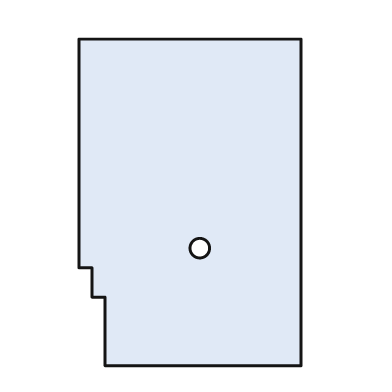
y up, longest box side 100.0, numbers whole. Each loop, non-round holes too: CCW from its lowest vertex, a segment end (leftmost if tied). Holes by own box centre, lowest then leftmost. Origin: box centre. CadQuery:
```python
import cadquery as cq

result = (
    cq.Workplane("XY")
    .moveTo(-26.0, -50.0)
    .lineTo(34.0, -50.0)
    .lineTo(34.0, 50.0)
    .lineTo(-34.0, 50.0)
    .lineTo(-34.0, -20.0)
    .lineTo(-30.0, -20.0)
    .lineTo(-30.0, -29.0)
    .lineTo(-26.0, -29.0)
    .close()
    .moveTo(3.0, -14.0)
    .circle(3.0)
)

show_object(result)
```